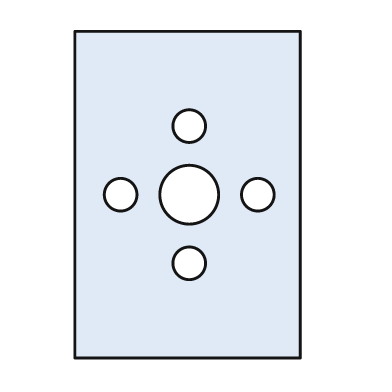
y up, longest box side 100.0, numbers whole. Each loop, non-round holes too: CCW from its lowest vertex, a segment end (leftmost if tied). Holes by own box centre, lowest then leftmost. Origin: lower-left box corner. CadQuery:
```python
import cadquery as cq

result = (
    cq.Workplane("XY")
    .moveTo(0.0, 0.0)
    .lineTo(69.0, 0.0)
    .lineTo(69.0, 100.0)
    .lineTo(0.0, 100.0)
    .close()
    .moveTo(35.0, 29.0)
    .circle(5.0)
    .moveTo(14.0, 50.0)
    .circle(5.0)
    .moveTo(35.0, 50.0)
    .circle(9.0)
    .moveTo(56.0, 50.0)
    .circle(5.0)
    .moveTo(35.0, 71.0)
    .circle(5.0)
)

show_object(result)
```